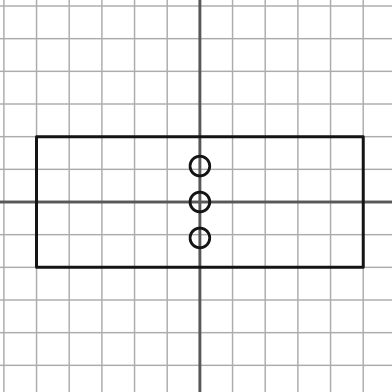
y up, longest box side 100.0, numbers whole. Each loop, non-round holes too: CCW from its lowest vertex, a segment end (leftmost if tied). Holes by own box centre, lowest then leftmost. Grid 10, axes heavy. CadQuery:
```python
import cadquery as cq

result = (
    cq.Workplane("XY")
    .moveTo(-50.0, -20.0)
    .lineTo(50.0, -20.0)
    .lineTo(50.0, 20.0)
    .lineTo(-50.0, 20.0)
    .close()
    .moveTo(0.0, -11.0)
    .circle(3.0)
    .moveTo(0.0, 0.0)
    .circle(3.0)
    .moveTo(0.0, 11.0)
    .circle(3.0)
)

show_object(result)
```